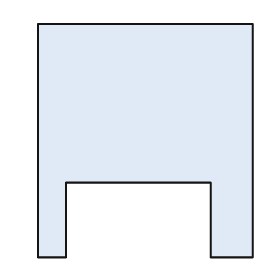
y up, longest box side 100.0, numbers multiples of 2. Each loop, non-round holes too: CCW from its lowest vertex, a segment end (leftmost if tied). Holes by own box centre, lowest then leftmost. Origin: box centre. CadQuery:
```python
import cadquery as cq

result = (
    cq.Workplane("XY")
    .moveTo(-46.0, -50.0)
    .lineTo(-34.0, -50.0)
    .lineTo(-34.0, -18.0)
    .lineTo(28.0, -18.0)
    .lineTo(28.0, -50.0)
    .lineTo(46.0, -50.0)
    .lineTo(46.0, 50.0)
    .lineTo(-46.0, 50.0)
    .close()
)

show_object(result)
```